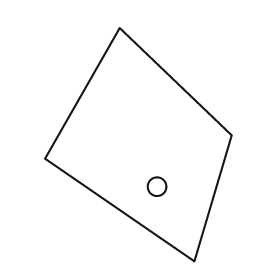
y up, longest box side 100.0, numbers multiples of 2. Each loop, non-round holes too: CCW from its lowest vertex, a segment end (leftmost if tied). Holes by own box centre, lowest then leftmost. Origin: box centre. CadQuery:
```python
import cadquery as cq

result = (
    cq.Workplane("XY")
    .moveTo(24.0, -50.0)
    .lineTo(40.0, 4.0)
    .lineTo(-8.0, 50.0)
    .lineTo(-40.0, -6.0)
    .close()
    .moveTo(8.0, -18.0)
    .circle(4.0)
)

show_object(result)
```